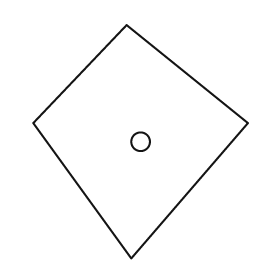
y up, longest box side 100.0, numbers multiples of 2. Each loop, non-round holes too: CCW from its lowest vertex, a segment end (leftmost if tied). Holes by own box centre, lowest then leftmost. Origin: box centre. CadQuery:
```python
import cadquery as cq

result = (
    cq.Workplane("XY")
    .moveTo(-4.0, -50.0)
    .lineTo(46.0, 8.0)
    .lineTo(-6.0, 50.0)
    .lineTo(-46.0, 8.0)
    .close()
    .moveTo(0.0, 0.0)
    .circle(4.0)
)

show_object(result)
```